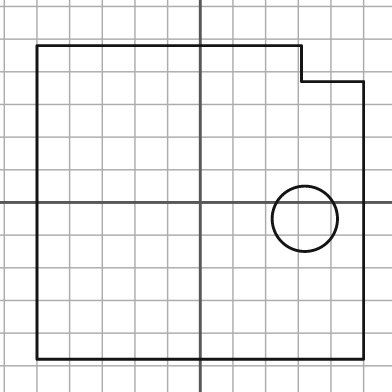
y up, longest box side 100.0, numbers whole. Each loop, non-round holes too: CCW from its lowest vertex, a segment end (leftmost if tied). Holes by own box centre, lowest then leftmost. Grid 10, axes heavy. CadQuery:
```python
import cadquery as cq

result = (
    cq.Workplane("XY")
    .moveTo(-50.0, -48.0)
    .lineTo(50.0, -48.0)
    .lineTo(50.0, 37.0)
    .lineTo(31.0, 37.0)
    .lineTo(31.0, 48.0)
    .lineTo(-50.0, 48.0)
    .close()
    .moveTo(32.0, -5.0)
    .circle(10.0)
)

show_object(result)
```